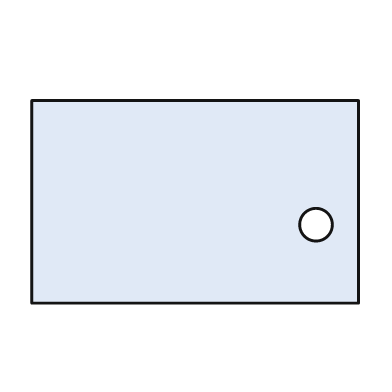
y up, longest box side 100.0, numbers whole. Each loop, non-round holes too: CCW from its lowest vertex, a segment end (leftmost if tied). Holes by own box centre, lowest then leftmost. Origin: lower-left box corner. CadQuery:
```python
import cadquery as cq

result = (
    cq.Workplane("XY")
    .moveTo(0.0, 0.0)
    .lineTo(100.0, 0.0)
    .lineTo(100.0, 62.0)
    .lineTo(0.0, 62.0)
    .close()
    .moveTo(87.0, 24.0)
    .circle(5.0)
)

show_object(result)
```